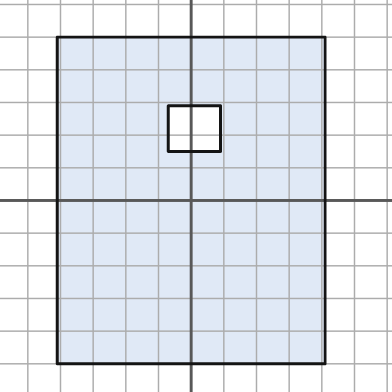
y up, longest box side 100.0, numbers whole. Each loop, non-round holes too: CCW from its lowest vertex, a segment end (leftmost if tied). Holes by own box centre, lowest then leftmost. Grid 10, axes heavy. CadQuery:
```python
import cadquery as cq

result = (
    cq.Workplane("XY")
    .moveTo(-41.0, -50.0)
    .lineTo(41.0, -50.0)
    .lineTo(41.0, 50.0)
    .lineTo(-41.0, 50.0)
    .close()
    .moveTo(-7.0, 15.0)
    .lineTo(9.0, 15.0)
    .lineTo(9.0, 29.0)
    .lineTo(-7.0, 29.0)
    .close()
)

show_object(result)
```